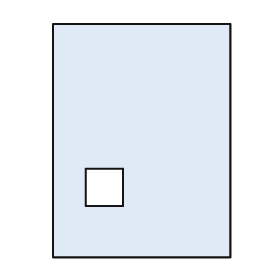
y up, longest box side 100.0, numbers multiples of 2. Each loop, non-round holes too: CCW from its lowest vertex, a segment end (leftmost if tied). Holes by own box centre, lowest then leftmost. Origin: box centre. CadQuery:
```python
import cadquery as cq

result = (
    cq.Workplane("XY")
    .moveTo(-38.0, -50.0)
    .lineTo(38.0, -50.0)
    .lineTo(38.0, 50.0)
    .lineTo(-38.0, 50.0)
    .close()
    .moveTo(-24.0, -28.0)
    .lineTo(-8.0, -28.0)
    .lineTo(-8.0, -12.0)
    .lineTo(-24.0, -12.0)
    .close()
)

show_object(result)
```